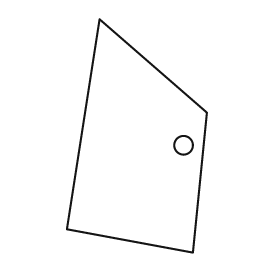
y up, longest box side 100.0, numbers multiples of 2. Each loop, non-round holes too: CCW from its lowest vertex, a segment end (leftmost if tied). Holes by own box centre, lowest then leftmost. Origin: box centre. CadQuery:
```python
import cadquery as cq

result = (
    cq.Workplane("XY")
    .moveTo(24.0, -50.0)
    .lineTo(30.0, 10.0)
    .lineTo(-16.0, 50.0)
    .lineTo(-30.0, -40.0)
    .close()
    .moveTo(20.0, -4.0)
    .circle(4.0)
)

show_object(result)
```